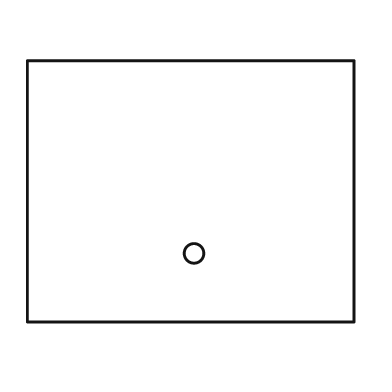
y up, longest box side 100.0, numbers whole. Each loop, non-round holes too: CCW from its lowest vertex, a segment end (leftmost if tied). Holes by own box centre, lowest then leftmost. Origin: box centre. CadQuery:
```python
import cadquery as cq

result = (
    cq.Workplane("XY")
    .moveTo(-50.0, -40.0)
    .lineTo(50.0, -40.0)
    .lineTo(50.0, 40.0)
    .lineTo(-50.0, 40.0)
    .close()
    .moveTo(1.0, -19.0)
    .circle(3.0)
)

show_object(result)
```